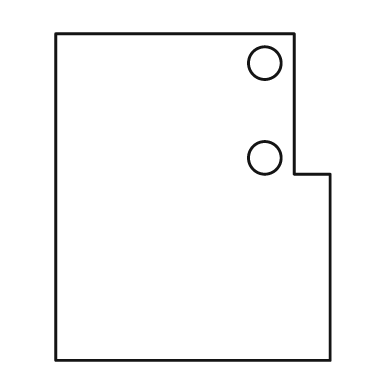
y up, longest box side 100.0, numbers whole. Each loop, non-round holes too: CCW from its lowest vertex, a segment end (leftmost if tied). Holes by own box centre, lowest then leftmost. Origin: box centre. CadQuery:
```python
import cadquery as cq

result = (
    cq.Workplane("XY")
    .moveTo(-42.0, -50.0)
    .lineTo(42.0, -50.0)
    .lineTo(42.0, 7.0)
    .lineTo(31.0, 7.0)
    .lineTo(31.0, 50.0)
    .lineTo(-42.0, 50.0)
    .close()
    .moveTo(22.0, 12.0)
    .circle(5.0)
    .moveTo(22.0, 41.0)
    .circle(5.0)
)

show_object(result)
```